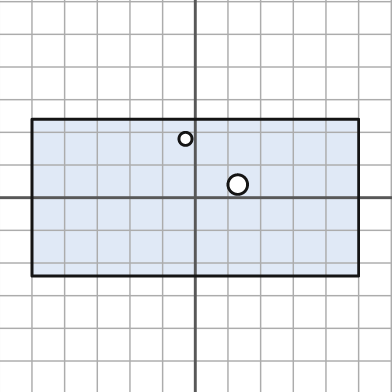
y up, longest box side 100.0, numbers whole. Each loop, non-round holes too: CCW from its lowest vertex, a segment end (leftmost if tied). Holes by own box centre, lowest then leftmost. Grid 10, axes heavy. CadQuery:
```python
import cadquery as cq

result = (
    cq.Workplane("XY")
    .moveTo(-50.0, -24.0)
    .lineTo(50.0, -24.0)
    .lineTo(50.0, 24.0)
    .lineTo(-50.0, 24.0)
    .close()
    .moveTo(13.0, 4.0)
    .circle(3.0)
    .moveTo(-3.0, 18.0)
    .circle(2.0)
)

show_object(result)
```